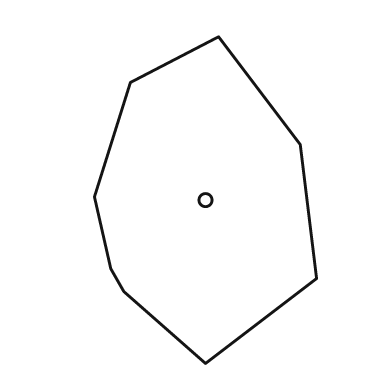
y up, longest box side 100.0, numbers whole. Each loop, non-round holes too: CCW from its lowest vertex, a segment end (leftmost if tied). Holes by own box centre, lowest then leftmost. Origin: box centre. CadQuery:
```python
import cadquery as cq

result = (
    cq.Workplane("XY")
    .moveTo(0.0, -50.0)
    .lineTo(34.0, -24.0)
    .lineTo(29.0, 17.0)
    .lineTo(4.0, 50.0)
    .lineTo(-23.0, 36.0)
    .lineTo(-34.0, 1.0)
    .lineTo(-29.0, -21.0)
    .lineTo(-25.0, -28.0)
    .close()
    .moveTo(0.0, 0.0)
    .circle(2.0)
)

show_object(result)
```